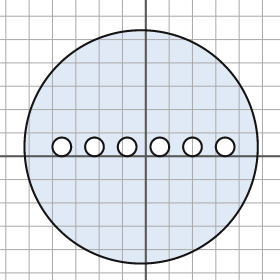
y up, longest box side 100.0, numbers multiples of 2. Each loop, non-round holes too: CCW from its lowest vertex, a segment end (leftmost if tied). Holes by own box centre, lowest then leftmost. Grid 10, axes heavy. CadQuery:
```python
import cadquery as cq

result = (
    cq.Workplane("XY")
    .moveTo(-2.0, 4.0)
    .circle(50.0)
    .moveTo(-36.0, 4.0)
    .circle(4.0)
    .moveTo(-22.0, 4.0)
    .circle(4.0)
    .moveTo(-8.0, 4.0)
    .circle(4.0)
    .moveTo(6.0, 4.0)
    .circle(4.0)
    .moveTo(20.0, 4.0)
    .circle(4.0)
    .moveTo(34.0, 4.0)
    .circle(4.0)
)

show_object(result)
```